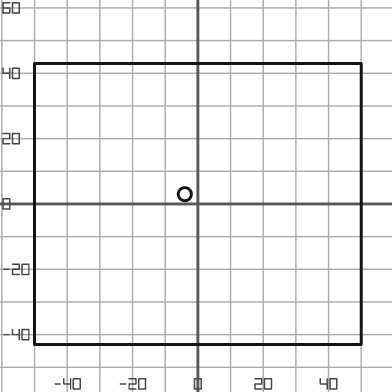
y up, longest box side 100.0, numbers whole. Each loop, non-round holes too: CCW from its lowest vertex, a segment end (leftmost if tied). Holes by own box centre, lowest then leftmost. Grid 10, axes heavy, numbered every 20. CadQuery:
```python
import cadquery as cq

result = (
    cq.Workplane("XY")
    .moveTo(-50.0, -43.0)
    .lineTo(50.0, -43.0)
    .lineTo(50.0, 43.0)
    .lineTo(-50.0, 43.0)
    .close()
    .moveTo(-4.0, 3.0)
    .circle(2.0)
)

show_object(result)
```